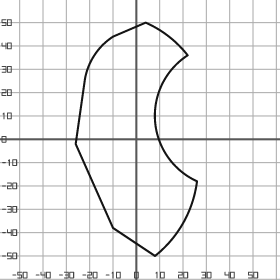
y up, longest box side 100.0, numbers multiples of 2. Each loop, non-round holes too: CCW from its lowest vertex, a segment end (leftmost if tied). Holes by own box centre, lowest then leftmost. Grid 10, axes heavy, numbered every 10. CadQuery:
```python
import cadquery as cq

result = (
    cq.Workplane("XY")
    .moveTo(8.0, -50.0)
    .threePointArc((20.0, -36.0), (26.0, -18.0))
    .threePointArc((8.0, 8.0), (22.0, 36.0))
    .threePointArc((14.0, 44.0), (4.0, 50.0))
    .lineTo(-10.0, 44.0)
    .threePointArc((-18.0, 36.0), (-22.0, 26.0))
    .lineTo(-26.0, -2.0)
    .lineTo(-10.0, -38.0)
    .close()
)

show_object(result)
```